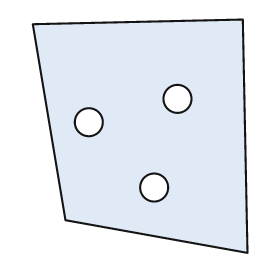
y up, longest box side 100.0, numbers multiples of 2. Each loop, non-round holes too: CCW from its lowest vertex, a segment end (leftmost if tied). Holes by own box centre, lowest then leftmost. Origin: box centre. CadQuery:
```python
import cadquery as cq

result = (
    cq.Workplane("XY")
    .moveTo(46.0, -50.0)
    .lineTo(44.0, 50.0)
    .lineTo(-46.0, 48.0)
    .lineTo(-32.0, -36.0)
    .close()
    .moveTo(6.0, -22.0)
    .circle(6.0)
    .moveTo(-22.0, 6.0)
    .circle(6.0)
    .moveTo(16.0, 16.0)
    .circle(6.0)
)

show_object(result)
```